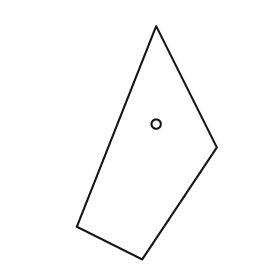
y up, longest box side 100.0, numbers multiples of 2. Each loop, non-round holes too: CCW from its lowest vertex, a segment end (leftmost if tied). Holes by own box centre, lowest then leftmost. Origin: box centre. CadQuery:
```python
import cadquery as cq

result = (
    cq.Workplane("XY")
    .moveTo(-2.0, -50.0)
    .lineTo(30.0, -2.0)
    .lineTo(4.0, 50.0)
    .lineTo(-30.0, -36.0)
    .close()
    .moveTo(4.0, 8.0)
    .circle(2.0)
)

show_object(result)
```